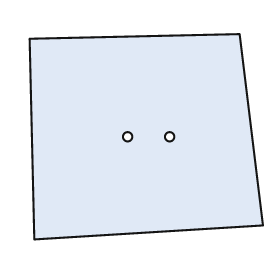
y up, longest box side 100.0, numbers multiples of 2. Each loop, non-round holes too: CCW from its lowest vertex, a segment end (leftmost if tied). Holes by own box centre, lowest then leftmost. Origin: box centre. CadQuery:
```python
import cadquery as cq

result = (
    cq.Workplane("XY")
    .moveTo(-48.0, -44.0)
    .lineTo(50.0, -38.0)
    .lineTo(40.0, 44.0)
    .lineTo(-50.0, 42.0)
    .close()
    .moveTo(-8.0, 0.0)
    .circle(2.0)
    .moveTo(10.0, 0.0)
    .circle(2.0)
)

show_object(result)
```